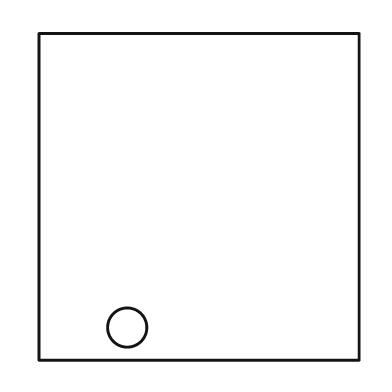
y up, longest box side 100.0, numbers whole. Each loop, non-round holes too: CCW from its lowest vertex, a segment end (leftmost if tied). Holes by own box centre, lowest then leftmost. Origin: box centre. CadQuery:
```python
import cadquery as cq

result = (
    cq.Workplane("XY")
    .moveTo(-49.0, -50.0)
    .lineTo(49.0, -50.0)
    .lineTo(49.0, 50.0)
    .lineTo(-49.0, 50.0)
    .close()
    .moveTo(-22.0, -40.0)
    .circle(6.0)
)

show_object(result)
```